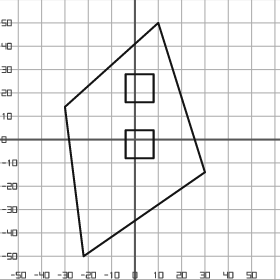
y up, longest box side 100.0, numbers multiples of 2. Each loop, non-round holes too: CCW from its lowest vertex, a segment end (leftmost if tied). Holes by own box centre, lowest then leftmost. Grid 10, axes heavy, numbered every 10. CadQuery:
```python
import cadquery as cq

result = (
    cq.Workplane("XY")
    .moveTo(-22.0, -50.0)
    .lineTo(30.0, -14.0)
    .lineTo(10.0, 50.0)
    .lineTo(-30.0, 14.0)
    .close()
    .moveTo(-4.0, -8.0)
    .lineTo(8.0, -8.0)
    .lineTo(8.0, 4.0)
    .lineTo(-4.0, 4.0)
    .close()
    .moveTo(-4.0, 16.0)
    .lineTo(8.0, 16.0)
    .lineTo(8.0, 28.0)
    .lineTo(-4.0, 28.0)
    .close()
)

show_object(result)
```